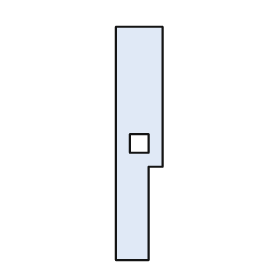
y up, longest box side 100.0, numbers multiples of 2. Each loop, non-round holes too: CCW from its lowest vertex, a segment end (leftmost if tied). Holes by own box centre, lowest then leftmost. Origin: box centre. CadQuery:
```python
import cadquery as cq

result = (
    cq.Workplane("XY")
    .moveTo(-10.0, -50.0)
    .lineTo(4.0, -50.0)
    .lineTo(4.0, -10.0)
    .lineTo(10.0, -10.0)
    .lineTo(10.0, 50.0)
    .lineTo(-10.0, 50.0)
    .close()
    .moveTo(-4.0, -4.0)
    .lineTo(4.0, -4.0)
    .lineTo(4.0, 4.0)
    .lineTo(-4.0, 4.0)
    .close()
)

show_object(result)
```